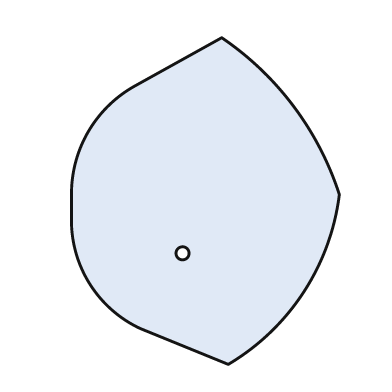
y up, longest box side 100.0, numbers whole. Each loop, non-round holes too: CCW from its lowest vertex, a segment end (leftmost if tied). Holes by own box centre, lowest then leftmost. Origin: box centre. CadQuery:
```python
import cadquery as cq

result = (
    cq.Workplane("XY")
    .moveTo(7.0, -50.0)
    .threePointArc((30.0, -28.0), (41.0, 2.0))
    .threePointArc((27.0, 29.0), (5.0, 50.0))
    .lineTo(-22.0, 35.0)
    .threePointArc((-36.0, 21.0), (-41.0, 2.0))
    .lineTo(-41.0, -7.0)
    .threePointArc((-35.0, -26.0), (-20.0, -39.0))
    .close()
    .moveTo(-7.0, -16.0)
    .circle(2.0)
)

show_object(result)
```